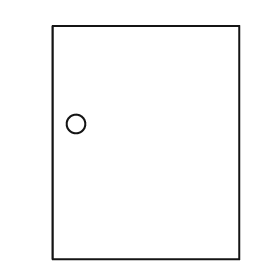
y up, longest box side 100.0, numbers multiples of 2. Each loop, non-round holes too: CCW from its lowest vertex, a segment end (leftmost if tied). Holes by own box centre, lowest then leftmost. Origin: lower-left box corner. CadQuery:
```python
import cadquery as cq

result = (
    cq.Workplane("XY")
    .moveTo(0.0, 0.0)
    .lineTo(80.0, 0.0)
    .lineTo(80.0, 100.0)
    .lineTo(0.0, 100.0)
    .close()
    .moveTo(10.0, 58.0)
    .circle(4.0)
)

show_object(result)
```